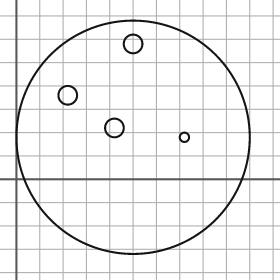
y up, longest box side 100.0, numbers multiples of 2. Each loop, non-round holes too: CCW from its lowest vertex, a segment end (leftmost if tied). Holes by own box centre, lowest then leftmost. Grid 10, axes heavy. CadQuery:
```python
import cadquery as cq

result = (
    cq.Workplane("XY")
    .moveTo(50.0, 18.0)
    .circle(50.0)
    .moveTo(72.0, 18.0)
    .circle(2.0)
    .moveTo(42.0, 22.0)
    .circle(4.0)
    .moveTo(22.0, 36.0)
    .circle(4.0)
    .moveTo(50.0, 58.0)
    .circle(4.0)
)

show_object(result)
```